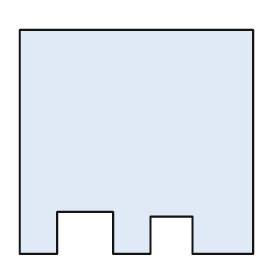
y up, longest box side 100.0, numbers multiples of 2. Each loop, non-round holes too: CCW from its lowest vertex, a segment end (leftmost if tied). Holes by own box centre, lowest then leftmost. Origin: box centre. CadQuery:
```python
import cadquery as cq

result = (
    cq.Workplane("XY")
    .moveTo(-50.0, -48.0)
    .lineTo(-34.0, -48.0)
    .lineTo(-34.0, -30.0)
    .lineTo(-10.0, -30.0)
    .lineTo(-10.0, -48.0)
    .lineTo(6.0, -48.0)
    .lineTo(6.0, -32.0)
    .lineTo(24.0, -32.0)
    .lineTo(24.0, -48.0)
    .lineTo(50.0, -48.0)
    .lineTo(50.0, 48.0)
    .lineTo(-50.0, 48.0)
    .close()
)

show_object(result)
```